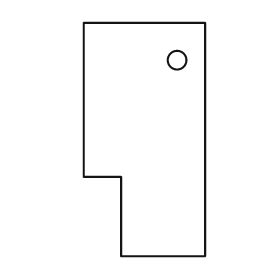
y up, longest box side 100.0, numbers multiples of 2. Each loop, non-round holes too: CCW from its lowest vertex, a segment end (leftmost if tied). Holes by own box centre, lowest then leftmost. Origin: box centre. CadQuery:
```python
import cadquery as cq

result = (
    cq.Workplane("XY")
    .moveTo(-10.0, -50.0)
    .lineTo(26.0, -50.0)
    .lineTo(26.0, 50.0)
    .lineTo(-26.0, 50.0)
    .lineTo(-26.0, -16.0)
    .lineTo(-10.0, -16.0)
    .close()
    .moveTo(14.0, 34.0)
    .circle(4.0)
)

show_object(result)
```